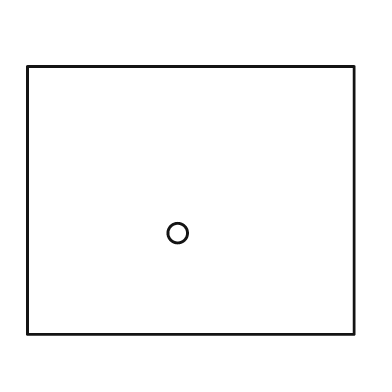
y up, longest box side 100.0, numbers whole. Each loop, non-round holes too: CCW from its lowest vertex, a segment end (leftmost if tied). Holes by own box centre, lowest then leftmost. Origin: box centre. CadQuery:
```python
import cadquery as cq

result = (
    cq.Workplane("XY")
    .moveTo(-50.0, -41.0)
    .lineTo(50.0, -41.0)
    .lineTo(50.0, 41.0)
    .lineTo(-50.0, 41.0)
    .close()
    .moveTo(-4.0, -10.0)
    .circle(3.0)
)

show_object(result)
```